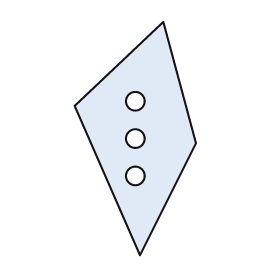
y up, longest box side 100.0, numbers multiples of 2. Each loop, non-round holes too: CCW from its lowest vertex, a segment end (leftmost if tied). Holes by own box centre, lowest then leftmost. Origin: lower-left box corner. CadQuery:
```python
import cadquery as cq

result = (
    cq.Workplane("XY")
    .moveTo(28.0, 0.0)
    .lineTo(52.0, 48.0)
    .lineTo(38.0, 100.0)
    .lineTo(0.0, 64.0)
    .close()
    .moveTo(26.0, 34.0)
    .circle(4.0)
    .moveTo(26.0, 50.0)
    .circle(4.0)
    .moveTo(26.0, 66.0)
    .circle(4.0)
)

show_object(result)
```